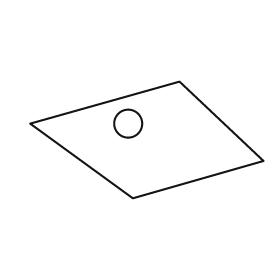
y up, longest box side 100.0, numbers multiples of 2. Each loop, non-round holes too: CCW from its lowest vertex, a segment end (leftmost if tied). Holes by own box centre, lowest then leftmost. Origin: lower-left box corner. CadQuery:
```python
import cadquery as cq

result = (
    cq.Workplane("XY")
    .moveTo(44.0, 0.0)
    .lineTo(100.0, 16.0)
    .lineTo(64.0, 50.0)
    .lineTo(0.0, 32.0)
    .close()
    .moveTo(42.0, 32.0)
    .circle(6.0)
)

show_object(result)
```